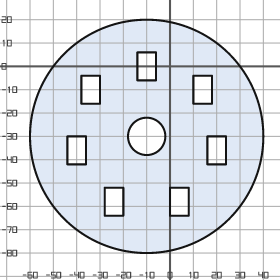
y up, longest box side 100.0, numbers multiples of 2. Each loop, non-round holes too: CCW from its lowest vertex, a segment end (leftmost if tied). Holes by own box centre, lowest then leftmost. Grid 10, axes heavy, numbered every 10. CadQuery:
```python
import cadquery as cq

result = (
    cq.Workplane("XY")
    .moveTo(-10.0, -30.0)
    .circle(50.0)
    .moveTo(-28.0, -64.0)
    .lineTo(-20.0, -64.0)
    .lineTo(-20.0, -52.0)
    .lineTo(-28.0, -52.0)
    .close()
    .moveTo(0.0, -64.0)
    .lineTo(8.0, -64.0)
    .lineTo(8.0, -52.0)
    .lineTo(0.0, -52.0)
    .close()
    .moveTo(-44.0, -42.0)
    .lineTo(-36.0, -42.0)
    .lineTo(-36.0, -30.0)
    .lineTo(-44.0, -30.0)
    .close()
    .moveTo(16.0, -42.0)
    .lineTo(24.0, -42.0)
    .lineTo(24.0, -30.0)
    .lineTo(16.0, -30.0)
    .close()
    .moveTo(-10.0, -30.0)
    .circle(8.0)
    .moveTo(-38.0, -16.0)
    .lineTo(-30.0, -16.0)
    .lineTo(-30.0, -4.0)
    .lineTo(-38.0, -4.0)
    .close()
    .moveTo(10.0, -16.0)
    .lineTo(18.0, -16.0)
    .lineTo(18.0, -4.0)
    .lineTo(10.0, -4.0)
    .close()
    .moveTo(-14.0, -6.0)
    .lineTo(-6.0, -6.0)
    .lineTo(-6.0, 6.0)
    .lineTo(-14.0, 6.0)
    .close()
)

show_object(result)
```